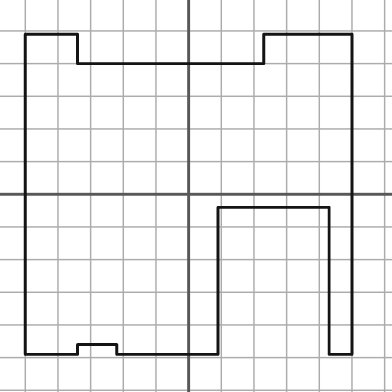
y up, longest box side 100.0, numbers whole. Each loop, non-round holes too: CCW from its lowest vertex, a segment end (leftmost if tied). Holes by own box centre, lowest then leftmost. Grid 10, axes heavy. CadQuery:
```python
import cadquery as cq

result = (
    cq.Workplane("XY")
    .moveTo(-50.0, -49.0)
    .lineTo(-34.0, -49.0)
    .lineTo(-34.0, -46.0)
    .lineTo(-22.0, -46.0)
    .lineTo(-22.0, -49.0)
    .lineTo(9.0, -49.0)
    .lineTo(9.0, -4.0)
    .lineTo(43.0, -4.0)
    .lineTo(43.0, -49.0)
    .lineTo(50.0, -49.0)
    .lineTo(50.0, 49.0)
    .lineTo(23.0, 49.0)
    .lineTo(23.0, 40.0)
    .lineTo(-34.0, 40.0)
    .lineTo(-34.0, 49.0)
    .lineTo(-50.0, 49.0)
    .close()
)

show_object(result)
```